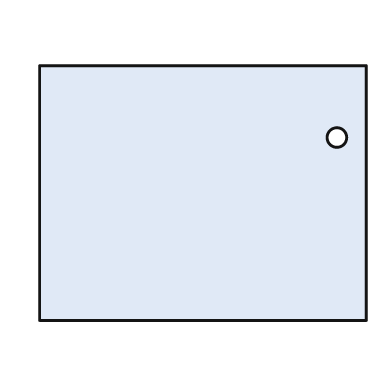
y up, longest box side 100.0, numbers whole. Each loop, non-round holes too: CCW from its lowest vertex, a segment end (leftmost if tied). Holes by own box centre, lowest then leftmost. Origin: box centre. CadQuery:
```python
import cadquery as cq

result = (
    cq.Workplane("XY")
    .moveTo(-50.0, -39.0)
    .lineTo(50.0, -39.0)
    .lineTo(50.0, 39.0)
    .lineTo(-50.0, 39.0)
    .close()
    .moveTo(41.0, 17.0)
    .circle(3.0)
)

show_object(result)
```